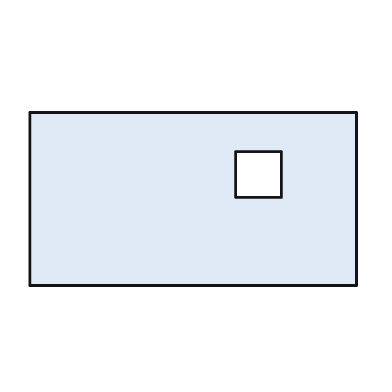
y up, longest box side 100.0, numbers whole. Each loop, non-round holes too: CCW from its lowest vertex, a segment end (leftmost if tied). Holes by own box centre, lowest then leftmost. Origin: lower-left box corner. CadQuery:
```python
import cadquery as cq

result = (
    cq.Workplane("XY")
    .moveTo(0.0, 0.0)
    .lineTo(100.0, 0.0)
    .lineTo(100.0, 53.0)
    .lineTo(0.0, 53.0)
    .close()
    .moveTo(63.0, 27.0)
    .lineTo(77.0, 27.0)
    .lineTo(77.0, 41.0)
    .lineTo(63.0, 41.0)
    .close()
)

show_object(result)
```